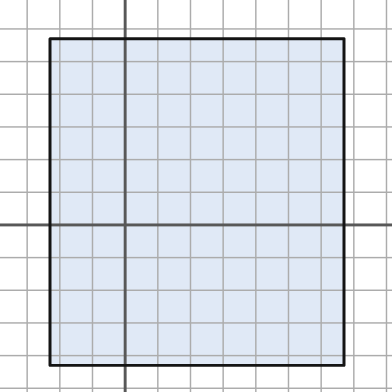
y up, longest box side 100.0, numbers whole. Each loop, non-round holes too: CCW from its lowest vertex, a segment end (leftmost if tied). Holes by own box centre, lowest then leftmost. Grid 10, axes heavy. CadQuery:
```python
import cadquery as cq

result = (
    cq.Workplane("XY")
    .moveTo(-23.0, -43.0)
    .lineTo(67.0, -43.0)
    .lineTo(67.0, 57.0)
    .lineTo(-23.0, 57.0)
    .close()
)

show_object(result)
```